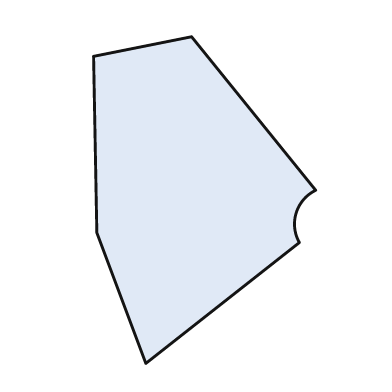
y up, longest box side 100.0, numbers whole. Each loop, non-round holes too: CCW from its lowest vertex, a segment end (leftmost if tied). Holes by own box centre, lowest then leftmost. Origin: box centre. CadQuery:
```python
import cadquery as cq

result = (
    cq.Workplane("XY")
    .moveTo(-18.0, -50.0)
    .lineTo(29.0, -13.0)
    .threePointArc((28.0, -4.0), (34.0, 3.0))
    .lineTo(-4.0, 50.0)
    .lineTo(-34.0, 44.0)
    .lineTo(-33.0, -10.0)
    .close()
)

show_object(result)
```